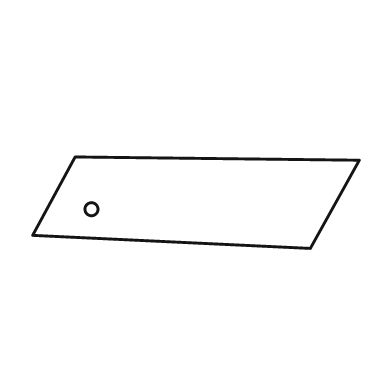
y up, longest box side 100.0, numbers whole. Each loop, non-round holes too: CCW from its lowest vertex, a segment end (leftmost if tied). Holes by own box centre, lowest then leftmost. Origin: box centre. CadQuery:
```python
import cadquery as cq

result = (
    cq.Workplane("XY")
    .moveTo(35.0, -14.0)
    .lineTo(50.0, 13.0)
    .lineTo(-37.0, 14.0)
    .lineTo(-50.0, -10.0)
    .close()
    .moveTo(-32.0, -2.0)
    .circle(2.0)
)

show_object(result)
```